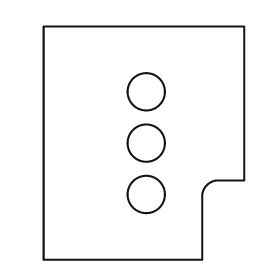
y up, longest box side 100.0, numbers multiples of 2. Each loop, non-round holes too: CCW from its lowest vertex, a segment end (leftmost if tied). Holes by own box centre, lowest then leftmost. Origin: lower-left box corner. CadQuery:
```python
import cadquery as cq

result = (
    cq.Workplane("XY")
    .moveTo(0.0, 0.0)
    .lineTo(68.0, 0.0)
    .lineTo(68.0, 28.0)
    .threePointArc((70.0, 32.0), (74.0, 34.0))
    .lineTo(86.0, 34.0)
    .lineTo(86.0, 100.0)
    .lineTo(0.0, 100.0)
    .close()
    .moveTo(44.0, 28.0)
    .circle(8.0)
    .moveTo(44.0, 50.0)
    .circle(8.0)
    .moveTo(44.0, 72.0)
    .circle(8.0)
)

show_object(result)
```